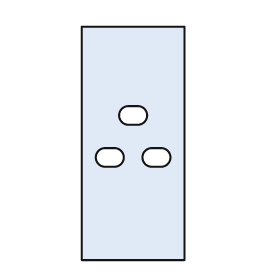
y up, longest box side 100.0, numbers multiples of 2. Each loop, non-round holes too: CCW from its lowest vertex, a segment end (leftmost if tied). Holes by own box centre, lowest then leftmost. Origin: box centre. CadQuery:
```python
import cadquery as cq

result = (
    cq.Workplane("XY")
    .moveTo(-22.0, -50.0)
    .lineTo(22.0, -50.0)
    .lineTo(22.0, 50.0)
    .lineTo(-22.0, 50.0)
    .close()
    .moveTo(-12.0, -10.0)
    .lineTo(-8.0, -10.0)
    .threePointArc((-4.0, -6.0), (-8.0, -2.0))
    .lineTo(-12.0, -2.0)
    .threePointArc((-16.0, -6.0), (-12.0, -10.0))
    .close()
    .moveTo(8.0, -10.0)
    .lineTo(12.0, -10.0)
    .threePointArc((16.0, -6.0), (12.0, -2.0))
    .lineTo(8.0, -2.0)
    .threePointArc((4.0, -6.0), (8.0, -10.0))
    .close()
    .moveTo(-2.0, 8.0)
    .lineTo(2.0, 8.0)
    .threePointArc((6.0, 12.0), (2.0, 16.0))
    .lineTo(-2.0, 16.0)
    .threePointArc((-6.0, 12.0), (-2.0, 8.0))
    .close()
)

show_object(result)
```